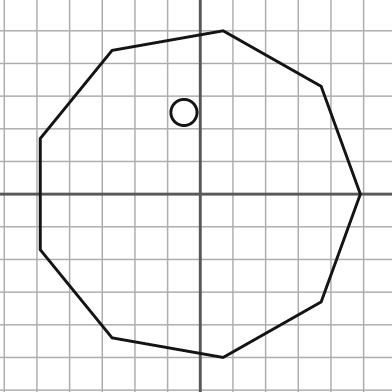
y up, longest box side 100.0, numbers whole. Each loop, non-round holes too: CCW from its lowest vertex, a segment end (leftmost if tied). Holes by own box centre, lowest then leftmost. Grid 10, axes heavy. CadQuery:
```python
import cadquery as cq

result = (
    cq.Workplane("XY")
    .moveTo(7.0, -50.0)
    .lineTo(37.0, -33.0)
    .lineTo(49.0, 0.0)
    .lineTo(37.0, 33.0)
    .lineTo(7.0, 50.0)
    .lineTo(-27.0, 44.0)
    .lineTo(-49.0, 17.0)
    .lineTo(-49.0, -17.0)
    .lineTo(-27.0, -44.0)
    .close()
    .moveTo(-5.0, 25.0)
    .circle(4.0)
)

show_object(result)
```